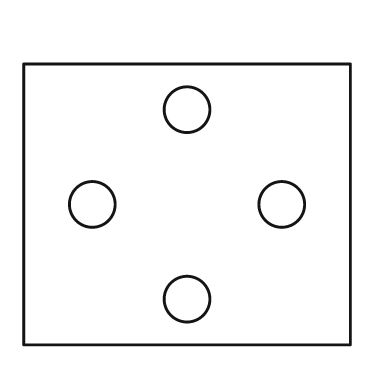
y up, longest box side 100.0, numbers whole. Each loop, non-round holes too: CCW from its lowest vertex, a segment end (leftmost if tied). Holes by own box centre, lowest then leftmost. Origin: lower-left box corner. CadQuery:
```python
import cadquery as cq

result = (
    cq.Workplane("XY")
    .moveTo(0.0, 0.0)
    .lineTo(100.0, 0.0)
    .lineTo(100.0, 86.0)
    .lineTo(0.0, 86.0)
    .close()
    .moveTo(50.0, 14.0)
    .circle(7.0)
    .moveTo(21.0, 43.0)
    .circle(7.0)
    .moveTo(79.0, 43.0)
    .circle(7.0)
    .moveTo(50.0, 72.0)
    .circle(7.0)
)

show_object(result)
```